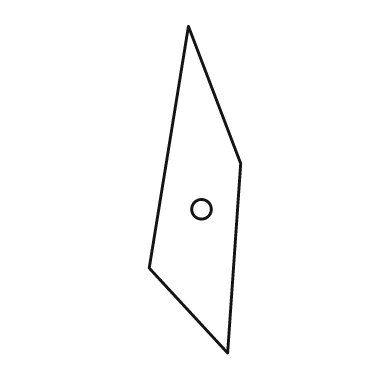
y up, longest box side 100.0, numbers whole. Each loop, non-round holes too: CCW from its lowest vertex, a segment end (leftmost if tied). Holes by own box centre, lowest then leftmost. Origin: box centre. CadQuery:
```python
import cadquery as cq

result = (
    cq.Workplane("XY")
    .moveTo(10.0, -50.0)
    .lineTo(14.0, 8.0)
    .lineTo(-2.0, 50.0)
    .lineTo(-14.0, -24.0)
    .close()
    .moveTo(2.0, -6.0)
    .circle(3.0)
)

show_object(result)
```